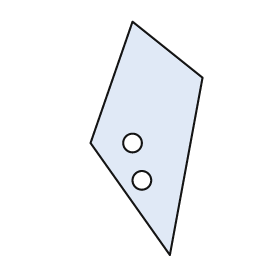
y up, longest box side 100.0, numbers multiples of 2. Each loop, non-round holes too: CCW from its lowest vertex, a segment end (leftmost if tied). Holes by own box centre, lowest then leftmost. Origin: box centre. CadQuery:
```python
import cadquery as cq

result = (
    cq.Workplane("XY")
    .moveTo(10.0, -50.0)
    .lineTo(24.0, 26.0)
    .lineTo(-6.0, 50.0)
    .lineTo(-24.0, -2.0)
    .close()
    .moveTo(-2.0, -18.0)
    .circle(4.0)
    .moveTo(-6.0, -2.0)
    .circle(4.0)
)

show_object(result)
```